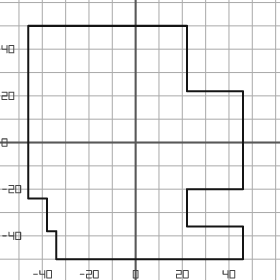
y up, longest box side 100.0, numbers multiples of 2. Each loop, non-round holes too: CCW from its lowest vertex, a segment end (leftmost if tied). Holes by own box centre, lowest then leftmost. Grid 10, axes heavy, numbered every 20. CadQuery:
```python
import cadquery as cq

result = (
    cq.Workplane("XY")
    .moveTo(-34.0, -50.0)
    .lineTo(46.0, -50.0)
    .lineTo(46.0, -36.0)
    .lineTo(22.0, -36.0)
    .lineTo(22.0, -20.0)
    .lineTo(46.0, -20.0)
    .lineTo(46.0, 22.0)
    .lineTo(22.0, 22.0)
    .lineTo(22.0, 50.0)
    .lineTo(-46.0, 50.0)
    .lineTo(-46.0, -24.0)
    .lineTo(-38.0, -24.0)
    .lineTo(-38.0, -38.0)
    .lineTo(-34.0, -38.0)
    .close()
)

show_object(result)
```